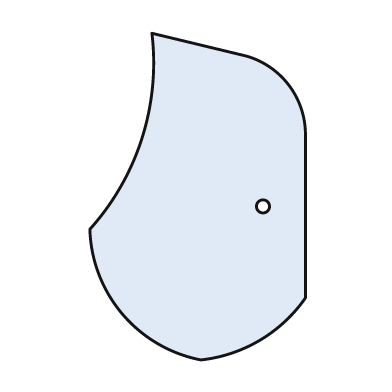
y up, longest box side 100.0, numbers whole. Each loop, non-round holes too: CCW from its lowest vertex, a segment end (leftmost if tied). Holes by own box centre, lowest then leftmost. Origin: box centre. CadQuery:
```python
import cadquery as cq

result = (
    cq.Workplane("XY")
    .moveTo(1.0, -50.0)
    .threePointArc((19.0, -44.0), (33.0, -31.0))
    .lineTo(33.0, 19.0)
    .threePointArc((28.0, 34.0), (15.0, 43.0))
    .lineTo(-14.0, 50.0)
    .threePointArc((-17.0, 18.0), (-33.0, -10.0))
    .threePointArc((-23.0, -36.0), (1.0, -50.0))
    .close()
    .moveTo(20.0, -3.0)
    .circle(2.0)
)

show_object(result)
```